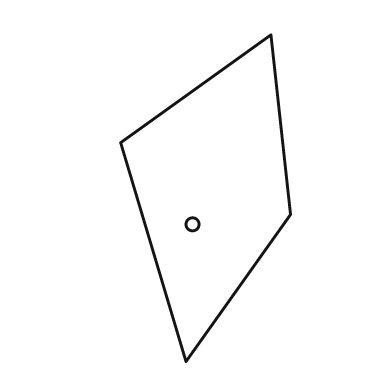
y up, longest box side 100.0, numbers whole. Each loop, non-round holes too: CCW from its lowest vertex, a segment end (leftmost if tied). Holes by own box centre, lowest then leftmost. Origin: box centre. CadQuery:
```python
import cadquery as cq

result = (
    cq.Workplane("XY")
    .moveTo(-6.0, -50.0)
    .lineTo(26.0, -5.0)
    .lineTo(20.0, 50.0)
    .lineTo(-26.0, 17.0)
    .close()
    .moveTo(-4.0, -8.0)
    .circle(2.0)
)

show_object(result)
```